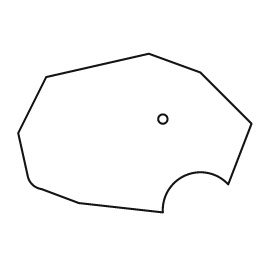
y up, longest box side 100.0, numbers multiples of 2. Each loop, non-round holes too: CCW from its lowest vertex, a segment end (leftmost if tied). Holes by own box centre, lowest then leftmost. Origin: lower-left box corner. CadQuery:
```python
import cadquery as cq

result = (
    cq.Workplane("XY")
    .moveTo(62.0, 0.0)
    .threePointArc((72.0, 16.0), (90.0, 12.0))
    .lineTo(100.0, 38.0)
    .lineTo(78.0, 60.0)
    .lineTo(56.0, 68.0)
    .lineTo(12.0, 58.0)
    .lineTo(0.0, 34.0)
    .lineTo(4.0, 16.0)
    .threePointArc((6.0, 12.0), (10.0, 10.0))
    .lineTo(26.0, 4.0)
    .close()
    .moveTo(62.0, 40.0)
    .circle(2.0)
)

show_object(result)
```